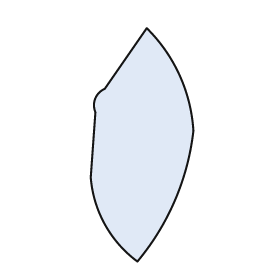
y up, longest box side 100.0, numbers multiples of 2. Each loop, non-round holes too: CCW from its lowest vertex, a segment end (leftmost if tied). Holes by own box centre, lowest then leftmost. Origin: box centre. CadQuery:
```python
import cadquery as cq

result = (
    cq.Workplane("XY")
    .moveTo(-2.0, -50.0)
    .threePointArc((14.0, -24.0), (22.0, 6.0))
    .threePointArc((16.0, 30.0), (2.0, 50.0))
    .lineTo(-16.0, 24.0)
    .threePointArc((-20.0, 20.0), (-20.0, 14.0))
    .lineTo(-22.0, -14.0)
    .threePointArc((-16.0, -34.0), (-2.0, -50.0))
    .close()
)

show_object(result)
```